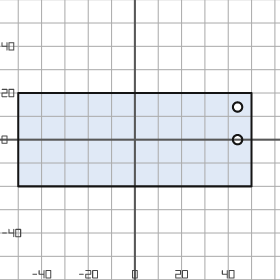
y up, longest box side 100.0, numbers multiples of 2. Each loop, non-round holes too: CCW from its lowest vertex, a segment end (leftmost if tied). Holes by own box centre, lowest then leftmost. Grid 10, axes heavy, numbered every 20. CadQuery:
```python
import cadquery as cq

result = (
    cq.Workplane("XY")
    .moveTo(-50.0, -20.0)
    .lineTo(50.0, -20.0)
    .lineTo(50.0, 20.0)
    .lineTo(-50.0, 20.0)
    .close()
    .moveTo(44.0, 0.0)
    .circle(2.0)
    .moveTo(44.0, 14.0)
    .circle(2.0)
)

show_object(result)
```